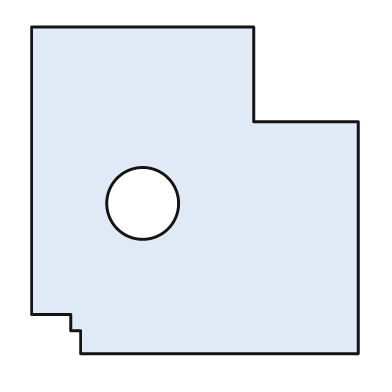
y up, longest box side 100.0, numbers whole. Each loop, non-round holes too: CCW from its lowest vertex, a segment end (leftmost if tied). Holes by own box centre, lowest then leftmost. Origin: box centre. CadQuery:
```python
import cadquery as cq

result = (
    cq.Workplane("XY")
    .moveTo(-35.0, -50.0)
    .lineTo(50.0, -50.0)
    .lineTo(50.0, 21.0)
    .lineTo(18.0, 21.0)
    .lineTo(18.0, 50.0)
    .lineTo(-50.0, 50.0)
    .lineTo(-50.0, -38.0)
    .lineTo(-38.0, -38.0)
    .lineTo(-38.0, -43.0)
    .lineTo(-35.0, -43.0)
    .close()
    .moveTo(-16.0, -4.0)
    .circle(11.0)
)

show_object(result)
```